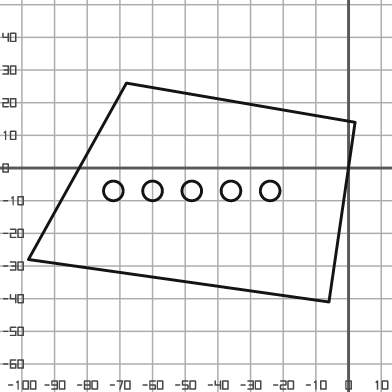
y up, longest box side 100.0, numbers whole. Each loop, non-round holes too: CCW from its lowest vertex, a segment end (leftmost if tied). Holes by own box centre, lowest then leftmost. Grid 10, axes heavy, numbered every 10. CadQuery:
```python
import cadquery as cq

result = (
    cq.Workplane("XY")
    .moveTo(-6.0, -41.0)
    .lineTo(2.0, 14.0)
    .lineTo(-68.0, 26.0)
    .lineTo(-98.0, -28.0)
    .close()
    .moveTo(-72.0, -7.0)
    .circle(3.0)
    .moveTo(-60.0, -7.0)
    .circle(3.0)
    .moveTo(-48.0, -7.0)
    .circle(3.0)
    .moveTo(-36.0, -7.0)
    .circle(3.0)
    .moveTo(-24.0, -7.0)
    .circle(3.0)
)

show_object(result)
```